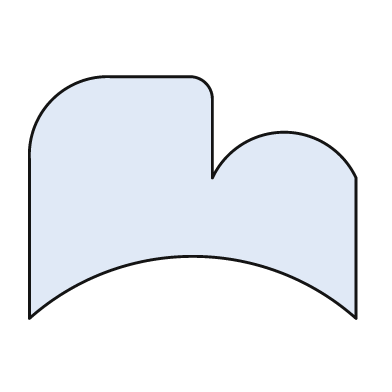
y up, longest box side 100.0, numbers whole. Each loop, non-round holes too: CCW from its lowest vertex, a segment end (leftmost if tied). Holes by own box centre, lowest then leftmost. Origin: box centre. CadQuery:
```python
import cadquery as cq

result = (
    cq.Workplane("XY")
    .moveTo(-50.0, -37.0)
    .threePointArc((0.0, -18.0), (50.0, -37.0))
    .lineTo(50.0, 6.0)
    .threePointArc((28.0, 20.0), (6.0, 6.0))
    .lineTo(6.0, 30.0)
    .threePointArc((4.0, 35.0), (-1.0, 37.0))
    .lineTo(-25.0, 37.0)
    .threePointArc((-43.0, 30.0), (-50.0, 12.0))
    .close()
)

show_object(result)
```